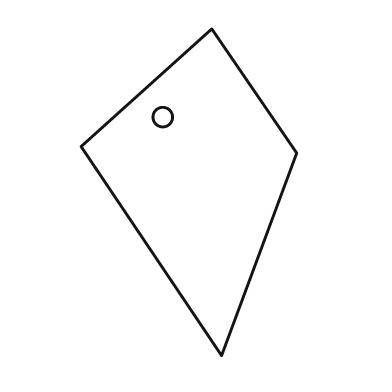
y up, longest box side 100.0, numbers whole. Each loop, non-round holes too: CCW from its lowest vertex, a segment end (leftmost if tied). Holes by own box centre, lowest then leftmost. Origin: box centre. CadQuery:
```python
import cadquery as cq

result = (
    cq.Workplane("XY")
    .moveTo(10.0, -50.0)
    .lineTo(33.0, 12.0)
    .lineTo(7.0, 50.0)
    .lineTo(-33.0, 14.0)
    .close()
    .moveTo(-8.0, 23.0)
    .circle(3.0)
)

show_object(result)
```